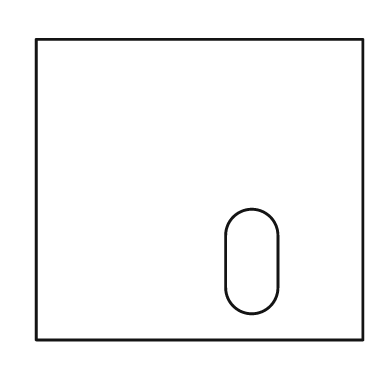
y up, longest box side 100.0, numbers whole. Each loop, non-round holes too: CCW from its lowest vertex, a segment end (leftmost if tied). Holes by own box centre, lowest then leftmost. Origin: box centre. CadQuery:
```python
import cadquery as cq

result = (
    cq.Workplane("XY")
    .moveTo(-50.0, -46.0)
    .lineTo(50.0, -46.0)
    .lineTo(50.0, 46.0)
    .lineTo(-50.0, 46.0)
    .close()
    .moveTo(8.0, -30.0)
    .threePointArc((16.0, -38.0), (24.0, -30.0))
    .lineTo(24.0, -14.0)
    .threePointArc((16.0, -6.0), (8.0, -14.0))
    .close()
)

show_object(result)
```